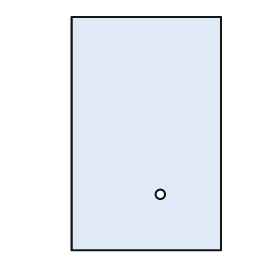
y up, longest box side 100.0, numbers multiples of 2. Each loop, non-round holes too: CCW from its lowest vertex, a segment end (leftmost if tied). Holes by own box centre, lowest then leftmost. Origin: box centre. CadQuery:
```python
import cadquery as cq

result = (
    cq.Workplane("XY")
    .moveTo(-32.0, -50.0)
    .lineTo(32.0, -50.0)
    .lineTo(32.0, 50.0)
    .lineTo(-32.0, 50.0)
    .close()
    .moveTo(6.0, -26.0)
    .circle(2.0)
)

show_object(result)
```